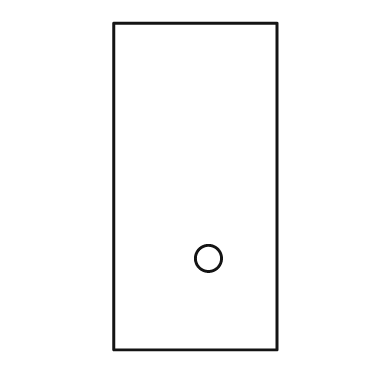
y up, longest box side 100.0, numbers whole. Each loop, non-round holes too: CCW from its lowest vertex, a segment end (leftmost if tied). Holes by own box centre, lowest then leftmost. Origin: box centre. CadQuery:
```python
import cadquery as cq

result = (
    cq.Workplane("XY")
    .moveTo(-25.0, -50.0)
    .lineTo(25.0, -50.0)
    .lineTo(25.0, 50.0)
    .lineTo(-25.0, 50.0)
    .close()
    .moveTo(4.0, -22.0)
    .circle(4.0)
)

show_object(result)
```